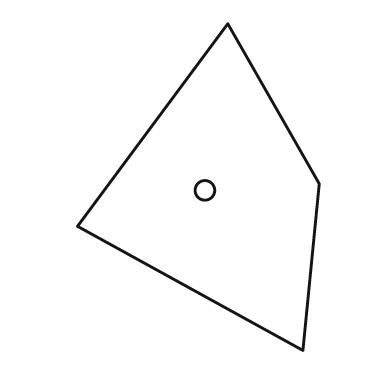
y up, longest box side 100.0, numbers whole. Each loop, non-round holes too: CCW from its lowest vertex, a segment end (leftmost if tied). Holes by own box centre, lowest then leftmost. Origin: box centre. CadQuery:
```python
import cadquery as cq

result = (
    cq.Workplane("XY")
    .moveTo(32.0, -50.0)
    .lineTo(37.0, 1.0)
    .lineTo(9.0, 50.0)
    .lineTo(-37.0, -12.0)
    .close()
    .moveTo(2.0, -1.0)
    .circle(3.0)
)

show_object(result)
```